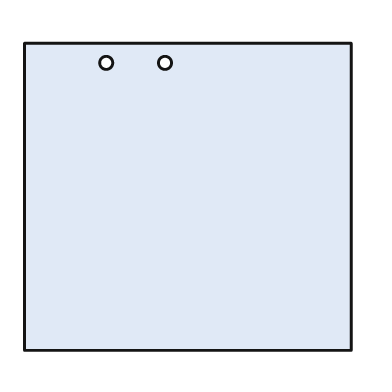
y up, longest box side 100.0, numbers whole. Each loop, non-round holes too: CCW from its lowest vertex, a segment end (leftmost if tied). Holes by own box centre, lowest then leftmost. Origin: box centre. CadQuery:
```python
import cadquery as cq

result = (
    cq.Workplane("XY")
    .moveTo(-50.0, -47.0)
    .lineTo(50.0, -47.0)
    .lineTo(50.0, 47.0)
    .lineTo(-50.0, 47.0)
    .close()
    .moveTo(-25.0, 41.0)
    .circle(2.0)
    .moveTo(-7.0, 41.0)
    .circle(2.0)
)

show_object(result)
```